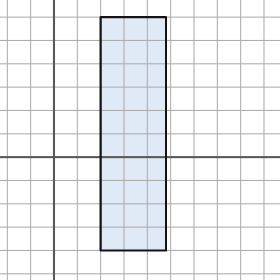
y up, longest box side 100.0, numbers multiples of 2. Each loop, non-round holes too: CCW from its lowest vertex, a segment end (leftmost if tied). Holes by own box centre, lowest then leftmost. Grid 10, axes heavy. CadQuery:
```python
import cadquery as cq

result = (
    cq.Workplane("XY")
    .moveTo(20.0, -40.0)
    .lineTo(48.0, -40.0)
    .lineTo(48.0, 60.0)
    .lineTo(20.0, 60.0)
    .close()
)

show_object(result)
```